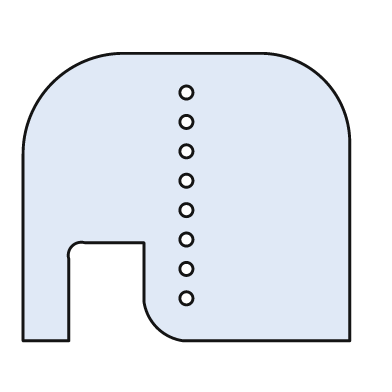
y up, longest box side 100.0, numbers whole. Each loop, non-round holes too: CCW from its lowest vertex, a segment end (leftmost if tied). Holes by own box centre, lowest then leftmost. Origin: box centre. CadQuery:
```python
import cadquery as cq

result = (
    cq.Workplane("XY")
    .moveTo(-50.0, -44.0)
    .lineTo(-36.0, -44.0)
    .lineTo(-36.0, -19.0)
    .threePointArc((-35.0, -15.0), (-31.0, -14.0))
    .lineTo(-13.0, -14.0)
    .lineTo(-13.0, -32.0)
    .threePointArc((-9.0, -40.0), (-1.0, -44.0))
    .lineTo(50.0, -44.0)
    .lineTo(50.0, 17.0)
    .threePointArc((42.0, 36.0), (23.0, 44.0))
    .lineTo(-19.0, 44.0)
    .threePointArc((-41.0, 35.0), (-50.0, 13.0))
    .close()
    .moveTo(0.0, -31.0)
    .circle(2.0)
    .moveTo(0.0, -22.0)
    .circle(2.0)
    .moveTo(0.0, -13.0)
    .circle(2.0)
    .moveTo(0.0, -4.0)
    .circle(2.0)
    .moveTo(0.0, 5.0)
    .circle(2.0)
    .moveTo(0.0, 14.0)
    .circle(2.0)
    .moveTo(0.0, 23.0)
    .circle(2.0)
    .moveTo(0.0, 32.0)
    .circle(2.0)
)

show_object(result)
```